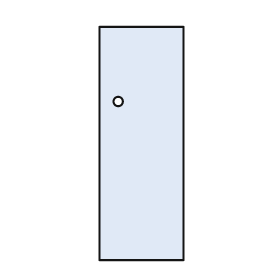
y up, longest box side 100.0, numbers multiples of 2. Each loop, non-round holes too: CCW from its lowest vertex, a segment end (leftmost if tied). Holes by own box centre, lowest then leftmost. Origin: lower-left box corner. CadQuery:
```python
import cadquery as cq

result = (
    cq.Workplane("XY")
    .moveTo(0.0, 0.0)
    .lineTo(36.0, 0.0)
    .lineTo(36.0, 100.0)
    .lineTo(0.0, 100.0)
    .close()
    .moveTo(8.0, 68.0)
    .circle(2.0)
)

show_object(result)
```